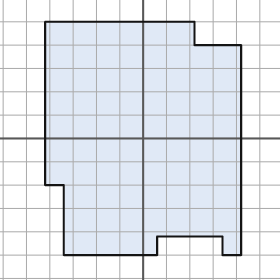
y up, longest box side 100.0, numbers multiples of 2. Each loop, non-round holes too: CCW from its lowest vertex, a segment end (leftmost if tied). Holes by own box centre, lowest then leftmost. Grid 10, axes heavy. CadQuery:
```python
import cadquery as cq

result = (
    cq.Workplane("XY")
    .moveTo(-34.0, -50.0)
    .lineTo(6.0, -50.0)
    .lineTo(6.0, -42.0)
    .lineTo(34.0, -42.0)
    .lineTo(34.0, -50.0)
    .lineTo(42.0, -50.0)
    .lineTo(42.0, 40.0)
    .lineTo(22.0, 40.0)
    .lineTo(22.0, 50.0)
    .lineTo(-42.0, 50.0)
    .lineTo(-42.0, -20.0)
    .lineTo(-34.0, -20.0)
    .close()
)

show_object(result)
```